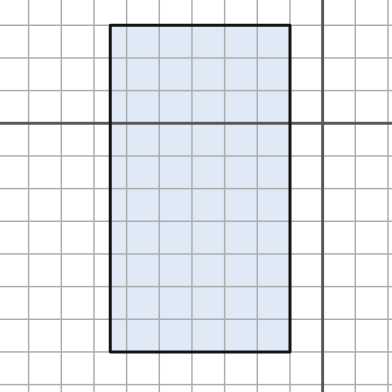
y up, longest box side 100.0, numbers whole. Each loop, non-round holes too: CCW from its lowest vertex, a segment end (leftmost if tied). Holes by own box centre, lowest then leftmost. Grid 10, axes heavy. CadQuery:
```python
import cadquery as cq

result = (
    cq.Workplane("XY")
    .moveTo(-65.0, -70.0)
    .lineTo(-10.0, -70.0)
    .lineTo(-10.0, 30.0)
    .lineTo(-65.0, 30.0)
    .close()
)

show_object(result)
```